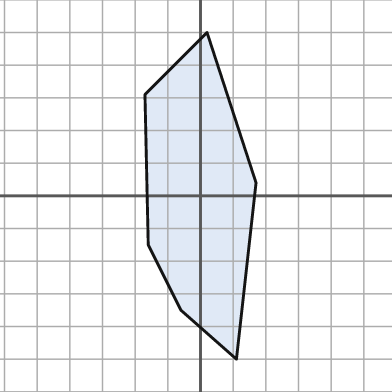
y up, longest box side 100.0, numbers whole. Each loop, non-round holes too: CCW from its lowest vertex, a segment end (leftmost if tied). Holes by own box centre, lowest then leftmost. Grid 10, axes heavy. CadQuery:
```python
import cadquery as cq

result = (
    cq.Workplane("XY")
    .moveTo(11.0, -50.0)
    .lineTo(17.0, 4.0)
    .lineTo(2.0, 50.0)
    .lineTo(-17.0, 31.0)
    .lineTo(-16.0, -15.0)
    .lineTo(-6.0, -35.0)
    .close()
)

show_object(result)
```